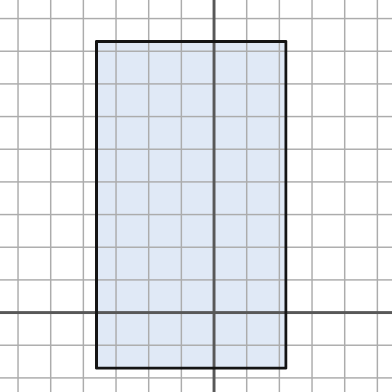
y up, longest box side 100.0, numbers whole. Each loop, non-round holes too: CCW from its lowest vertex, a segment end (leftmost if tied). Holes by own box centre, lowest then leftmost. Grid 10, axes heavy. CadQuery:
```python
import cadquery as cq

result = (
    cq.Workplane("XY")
    .moveTo(-36.0, -17.0)
    .lineTo(22.0, -17.0)
    .lineTo(22.0, 83.0)
    .lineTo(-36.0, 83.0)
    .close()
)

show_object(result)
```